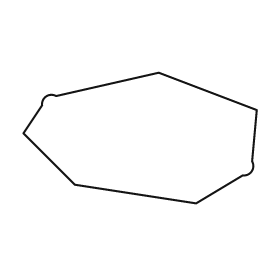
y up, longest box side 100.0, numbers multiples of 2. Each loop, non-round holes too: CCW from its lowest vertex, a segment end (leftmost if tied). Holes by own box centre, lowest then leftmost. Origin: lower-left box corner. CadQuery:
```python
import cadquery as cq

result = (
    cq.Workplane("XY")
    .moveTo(74.0, 0.0)
    .lineTo(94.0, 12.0)
    .threePointArc((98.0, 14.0), (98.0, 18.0))
    .lineTo(100.0, 40.0)
    .lineTo(58.0, 56.0)
    .lineTo(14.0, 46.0)
    .threePointArc((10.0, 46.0), (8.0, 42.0))
    .lineTo(0.0, 30.0)
    .lineTo(22.0, 8.0)
    .close()
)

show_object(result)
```